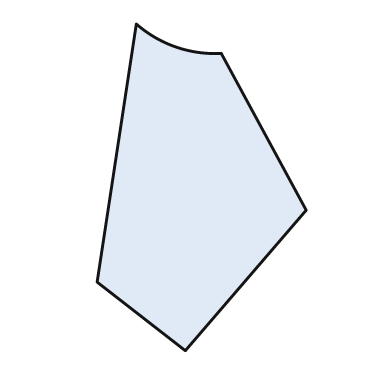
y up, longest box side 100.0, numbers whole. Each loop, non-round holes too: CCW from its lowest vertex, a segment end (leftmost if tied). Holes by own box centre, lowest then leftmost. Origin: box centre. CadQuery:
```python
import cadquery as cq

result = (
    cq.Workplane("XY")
    .moveTo(-5.0, -50.0)
    .lineTo(32.0, -7.0)
    .lineTo(6.0, 41.0)
    .threePointArc((-8.0, 43.0), (-20.0, 50.0))
    .lineTo(-32.0, -29.0)
    .close()
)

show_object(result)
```